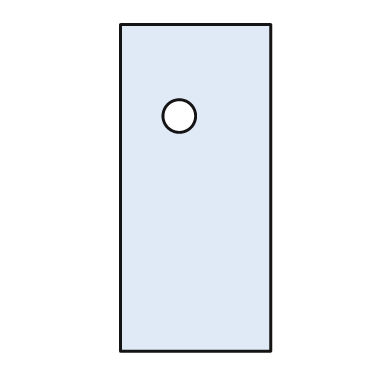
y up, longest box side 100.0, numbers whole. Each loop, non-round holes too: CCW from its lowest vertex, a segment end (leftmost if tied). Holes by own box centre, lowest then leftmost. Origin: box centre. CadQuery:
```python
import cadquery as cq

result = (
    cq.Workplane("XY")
    .moveTo(-23.0, -50.0)
    .lineTo(23.0, -50.0)
    .lineTo(23.0, 50.0)
    .lineTo(-23.0, 50.0)
    .close()
    .moveTo(-5.0, 22.0)
    .circle(5.0)
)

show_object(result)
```